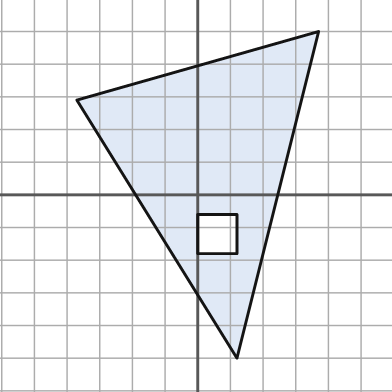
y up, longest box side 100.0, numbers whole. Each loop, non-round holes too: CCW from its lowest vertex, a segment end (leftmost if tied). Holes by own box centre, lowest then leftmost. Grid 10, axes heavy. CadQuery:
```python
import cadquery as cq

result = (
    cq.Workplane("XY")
    .moveTo(12.0, -50.0)
    .lineTo(37.0, 50.0)
    .lineTo(-37.0, 29.0)
    .close()
    .moveTo(0.0, -18.0)
    .lineTo(12.0, -18.0)
    .lineTo(12.0, -6.0)
    .lineTo(0.0, -6.0)
    .close()
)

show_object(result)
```